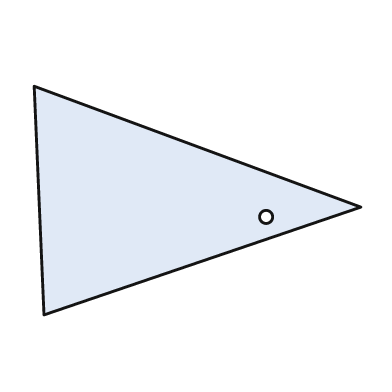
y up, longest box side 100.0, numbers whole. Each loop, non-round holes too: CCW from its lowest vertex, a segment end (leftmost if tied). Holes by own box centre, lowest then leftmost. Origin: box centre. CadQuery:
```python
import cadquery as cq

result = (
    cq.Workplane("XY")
    .moveTo(-47.0, -35.0)
    .lineTo(50.0, -2.0)
    .lineTo(-50.0, 35.0)
    .close()
    .moveTo(21.0, -5.0)
    .circle(2.0)
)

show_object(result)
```